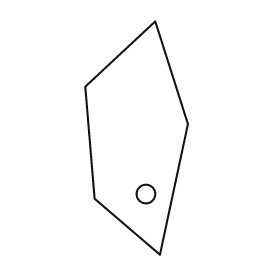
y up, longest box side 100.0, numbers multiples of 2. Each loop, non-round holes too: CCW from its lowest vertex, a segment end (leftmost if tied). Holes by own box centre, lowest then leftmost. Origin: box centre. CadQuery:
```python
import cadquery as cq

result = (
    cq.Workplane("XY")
    .moveTo(10.0, -50.0)
    .lineTo(22.0, 6.0)
    .lineTo(8.0, 50.0)
    .lineTo(-22.0, 22.0)
    .lineTo(-18.0, -26.0)
    .close()
    .moveTo(4.0, -24.0)
    .circle(4.0)
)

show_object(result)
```